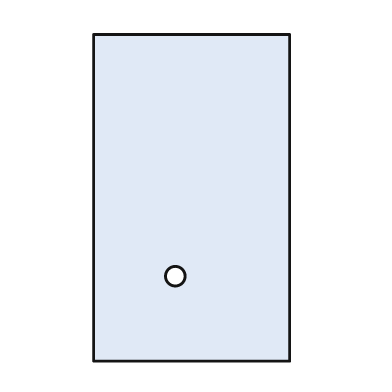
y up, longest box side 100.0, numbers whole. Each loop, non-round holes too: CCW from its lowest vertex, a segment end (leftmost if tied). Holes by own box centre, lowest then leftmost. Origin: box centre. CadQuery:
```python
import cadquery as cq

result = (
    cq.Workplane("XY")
    .moveTo(-30.0, -50.0)
    .lineTo(30.0, -50.0)
    .lineTo(30.0, 50.0)
    .lineTo(-30.0, 50.0)
    .close()
    .moveTo(-5.0, -24.0)
    .circle(3.0)
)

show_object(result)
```